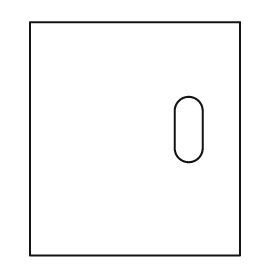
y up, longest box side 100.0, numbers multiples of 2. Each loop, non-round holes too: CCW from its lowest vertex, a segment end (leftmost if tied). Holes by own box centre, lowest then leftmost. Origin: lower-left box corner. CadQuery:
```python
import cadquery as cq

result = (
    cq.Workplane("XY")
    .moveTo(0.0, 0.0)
    .lineTo(90.0, 0.0)
    .lineTo(90.0, 100.0)
    .lineTo(0.0, 100.0)
    .close()
    .moveTo(62.0, 46.0)
    .threePointArc((68.0, 40.0), (74.0, 46.0))
    .lineTo(74.0, 62.0)
    .threePointArc((68.0, 68.0), (62.0, 62.0))
    .close()
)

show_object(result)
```